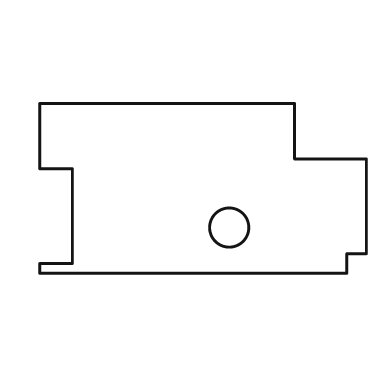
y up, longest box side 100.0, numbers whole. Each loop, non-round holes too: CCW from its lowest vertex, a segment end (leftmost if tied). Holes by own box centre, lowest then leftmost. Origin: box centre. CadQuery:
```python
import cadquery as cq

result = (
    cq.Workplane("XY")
    .moveTo(-50.0, -26.0)
    .lineTo(44.0, -26.0)
    .lineTo(44.0, -20.0)
    .lineTo(50.0, -20.0)
    .lineTo(50.0, 9.0)
    .lineTo(28.0, 9.0)
    .lineTo(28.0, 26.0)
    .lineTo(-50.0, 26.0)
    .lineTo(-50.0, 6.0)
    .lineTo(-40.0, 6.0)
    .lineTo(-40.0, -23.0)
    .lineTo(-50.0, -23.0)
    .close()
    .moveTo(8.0, -12.0)
    .circle(6.0)
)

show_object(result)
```